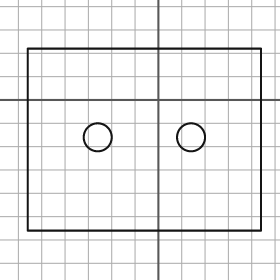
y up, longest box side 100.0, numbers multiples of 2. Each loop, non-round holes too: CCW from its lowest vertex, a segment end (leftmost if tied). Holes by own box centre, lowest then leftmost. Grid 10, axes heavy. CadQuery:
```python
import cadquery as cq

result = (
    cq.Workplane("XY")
    .moveTo(-56.0, -56.0)
    .lineTo(44.0, -56.0)
    .lineTo(44.0, 22.0)
    .lineTo(-56.0, 22.0)
    .close()
    .moveTo(-26.0, -16.0)
    .circle(6.0)
    .moveTo(14.0, -16.0)
    .circle(6.0)
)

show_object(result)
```